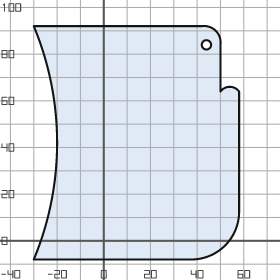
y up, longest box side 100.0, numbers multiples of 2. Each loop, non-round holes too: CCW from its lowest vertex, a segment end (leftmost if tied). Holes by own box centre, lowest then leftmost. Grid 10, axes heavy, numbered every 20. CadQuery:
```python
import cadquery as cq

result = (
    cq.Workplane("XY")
    .moveTo(-30.0, -8.0)
    .lineTo(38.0, -8.0)
    .threePointArc((52.0, -2.0), (58.0, 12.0))
    .lineTo(58.0, 64.0)
    .threePointArc((54.0, 66.0), (50.0, 64.0))
    .lineTo(50.0, 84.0)
    .threePointArc((48.0, 90.0), (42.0, 92.0))
    .lineTo(-30.0, 92.0)
    .threePointArc((-20.0, 42.0), (-30.0, -8.0))
    .close()
    .moveTo(44.0, 84.0)
    .circle(2.0)
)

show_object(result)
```